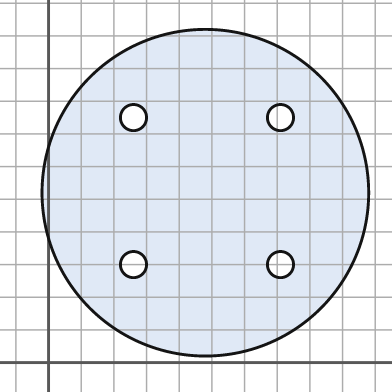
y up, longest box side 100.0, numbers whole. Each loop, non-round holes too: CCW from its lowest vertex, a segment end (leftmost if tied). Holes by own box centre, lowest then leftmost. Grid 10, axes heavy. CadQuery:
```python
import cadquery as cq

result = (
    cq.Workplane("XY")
    .moveTo(48.0, 52.0)
    .circle(50.0)
    .moveTo(26.0, 30.0)
    .circle(4.0)
    .moveTo(71.0, 30.0)
    .circle(4.0)
    .moveTo(26.0, 75.0)
    .circle(4.0)
    .moveTo(71.0, 75.0)
    .circle(4.0)
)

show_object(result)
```